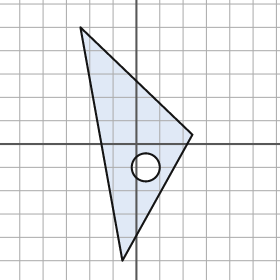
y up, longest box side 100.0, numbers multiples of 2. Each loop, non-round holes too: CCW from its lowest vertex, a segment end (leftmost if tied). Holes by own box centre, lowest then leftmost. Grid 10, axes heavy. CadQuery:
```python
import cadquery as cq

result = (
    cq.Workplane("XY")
    .moveTo(-6.0, -50.0)
    .lineTo(24.0, 4.0)
    .lineTo(-24.0, 50.0)
    .close()
    .moveTo(4.0, -10.0)
    .circle(6.0)
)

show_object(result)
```